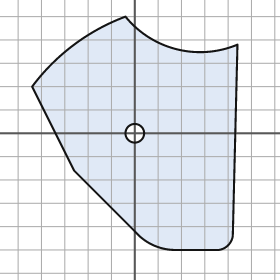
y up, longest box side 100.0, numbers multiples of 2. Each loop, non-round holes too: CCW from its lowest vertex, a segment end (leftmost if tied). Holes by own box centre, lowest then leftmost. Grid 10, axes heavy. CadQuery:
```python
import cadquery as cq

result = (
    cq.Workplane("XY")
    .moveTo(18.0, -50.0)
    .lineTo(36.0, -50.0)
    .threePointArc((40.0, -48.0), (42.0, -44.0))
    .lineTo(44.0, 38.0)
    .threePointArc((18.0, 36.0), (-4.0, 50.0))
    .threePointArc((-26.0, 38.0), (-44.0, 20.0))
    .lineTo(-26.0, -16.0)
    .lineTo(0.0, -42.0)
    .threePointArc((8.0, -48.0), (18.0, -50.0))
    .close()
    .moveTo(0.0, 0.0)
    .circle(4.0)
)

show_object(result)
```